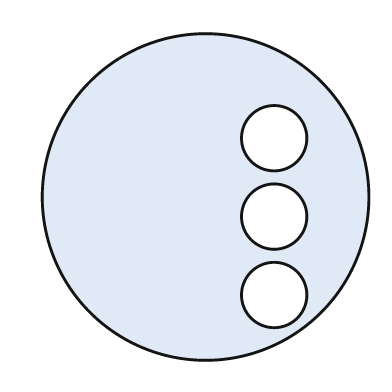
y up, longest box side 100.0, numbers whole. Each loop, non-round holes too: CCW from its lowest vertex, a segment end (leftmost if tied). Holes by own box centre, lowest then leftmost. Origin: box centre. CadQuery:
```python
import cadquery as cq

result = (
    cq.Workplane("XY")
    .moveTo(0.0, 0.0)
    .circle(50.0)
    .moveTo(21.0, -30.0)
    .circle(10.0)
    .moveTo(21.0, -6.0)
    .circle(10.0)
    .moveTo(21.0, 18.0)
    .circle(10.0)
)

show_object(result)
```